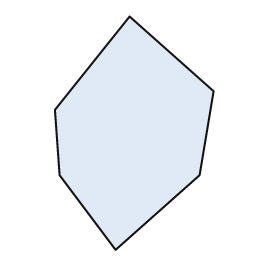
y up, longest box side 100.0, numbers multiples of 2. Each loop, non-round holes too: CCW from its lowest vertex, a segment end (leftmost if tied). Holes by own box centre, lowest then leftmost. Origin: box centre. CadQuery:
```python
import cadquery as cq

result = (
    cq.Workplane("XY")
    .moveTo(-8.0, -50.0)
    .lineTo(28.0, -18.0)
    .lineTo(34.0, 18.0)
    .lineTo(-2.0, 50.0)
    .lineTo(-34.0, 10.0)
    .lineTo(-32.0, -18.0)
    .close()
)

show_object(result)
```